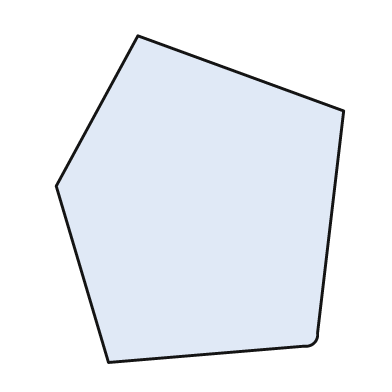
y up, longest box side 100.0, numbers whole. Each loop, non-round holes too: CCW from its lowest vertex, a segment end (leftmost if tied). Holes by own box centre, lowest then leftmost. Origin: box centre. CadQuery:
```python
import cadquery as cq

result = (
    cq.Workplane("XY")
    .moveTo(-28.0, -50.0)
    .lineTo(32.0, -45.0)
    .threePointArc((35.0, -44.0), (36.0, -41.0))
    .lineTo(44.0, 27.0)
    .lineTo(-19.0, 50.0)
    .lineTo(-44.0, 4.0)
    .close()
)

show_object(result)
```